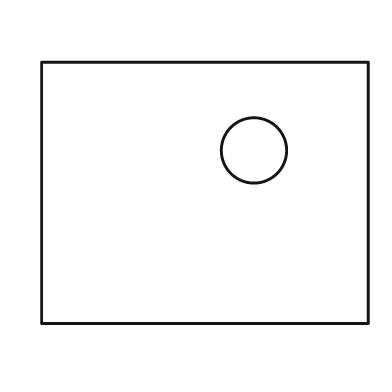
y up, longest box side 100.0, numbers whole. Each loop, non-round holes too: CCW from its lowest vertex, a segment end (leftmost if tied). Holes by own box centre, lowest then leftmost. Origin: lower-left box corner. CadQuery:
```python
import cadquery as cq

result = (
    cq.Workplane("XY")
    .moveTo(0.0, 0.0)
    .lineTo(100.0, 0.0)
    .lineTo(100.0, 80.0)
    .lineTo(0.0, 80.0)
    .close()
    .moveTo(65.0, 53.0)
    .circle(10.0)
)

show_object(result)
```